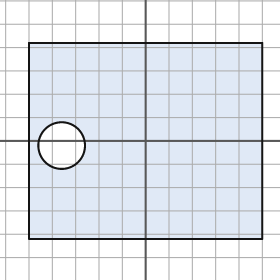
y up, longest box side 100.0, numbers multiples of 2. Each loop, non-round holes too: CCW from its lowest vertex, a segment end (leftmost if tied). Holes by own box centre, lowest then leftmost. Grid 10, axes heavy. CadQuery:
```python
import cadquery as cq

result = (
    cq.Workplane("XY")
    .moveTo(-50.0, -42.0)
    .lineTo(50.0, -42.0)
    .lineTo(50.0, 42.0)
    .lineTo(-50.0, 42.0)
    .close()
    .moveTo(-36.0, -2.0)
    .circle(10.0)
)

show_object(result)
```